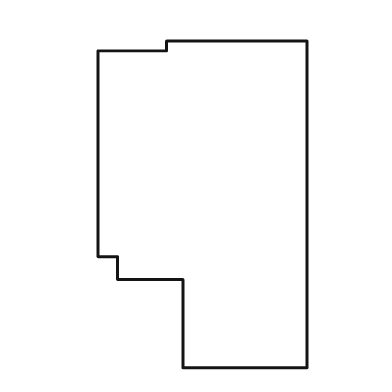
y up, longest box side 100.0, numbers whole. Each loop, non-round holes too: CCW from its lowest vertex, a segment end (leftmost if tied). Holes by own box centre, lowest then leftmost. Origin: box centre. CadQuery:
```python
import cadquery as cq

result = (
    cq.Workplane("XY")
    .moveTo(-6.0, -50.0)
    .lineTo(32.0, -50.0)
    .lineTo(32.0, 50.0)
    .lineTo(-11.0, 50.0)
    .lineTo(-11.0, 47.0)
    .lineTo(-32.0, 47.0)
    .lineTo(-32.0, -16.0)
    .lineTo(-26.0, -16.0)
    .lineTo(-26.0, -23.0)
    .lineTo(-6.0, -23.0)
    .close()
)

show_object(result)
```